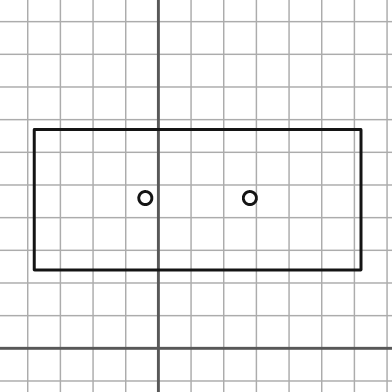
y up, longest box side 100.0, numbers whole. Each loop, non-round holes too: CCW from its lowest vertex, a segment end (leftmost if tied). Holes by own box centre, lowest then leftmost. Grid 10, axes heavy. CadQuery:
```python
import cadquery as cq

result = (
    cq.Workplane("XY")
    .moveTo(-38.0, 24.0)
    .lineTo(62.0, 24.0)
    .lineTo(62.0, 67.0)
    .lineTo(-38.0, 67.0)
    .close()
    .moveTo(-4.0, 46.0)
    .circle(2.0)
    .moveTo(28.0, 46.0)
    .circle(2.0)
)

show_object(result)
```